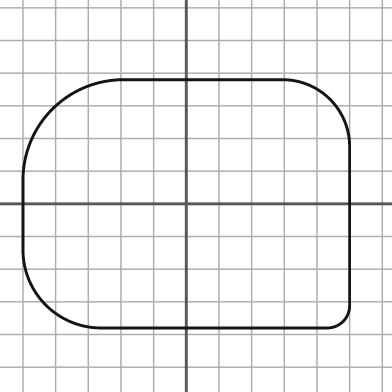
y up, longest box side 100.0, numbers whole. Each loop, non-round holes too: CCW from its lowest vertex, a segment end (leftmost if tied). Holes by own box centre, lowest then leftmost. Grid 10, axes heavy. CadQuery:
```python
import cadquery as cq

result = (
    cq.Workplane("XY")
    .moveTo(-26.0, -38.0)
    .lineTo(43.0, -38.0)
    .threePointArc((48.0, -36.0), (50.0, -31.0))
    .lineTo(50.0, 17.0)
    .threePointArc((44.0, 32.0), (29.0, 38.0))
    .lineTo(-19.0, 38.0)
    .threePointArc((-41.0, 29.0), (-50.0, 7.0))
    .lineTo(-50.0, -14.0)
    .threePointArc((-43.0, -31.0), (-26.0, -38.0))
    .close()
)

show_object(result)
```